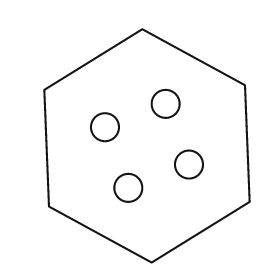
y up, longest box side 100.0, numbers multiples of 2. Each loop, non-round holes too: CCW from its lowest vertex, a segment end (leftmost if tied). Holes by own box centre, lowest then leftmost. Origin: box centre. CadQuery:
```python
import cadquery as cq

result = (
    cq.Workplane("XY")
    .moveTo(2.0, -50.0)
    .lineTo(44.0, -24.0)
    .lineTo(42.0, 26.0)
    .lineTo(-2.0, 50.0)
    .lineTo(-44.0, 24.0)
    .lineTo(-42.0, -26.0)
    .close()
    .moveTo(-8.0, -18.0)
    .circle(6.0)
    .moveTo(18.0, -8.0)
    .circle(6.0)
    .moveTo(-18.0, 8.0)
    .circle(6.0)
    .moveTo(8.0, 18.0)
    .circle(6.0)
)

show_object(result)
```